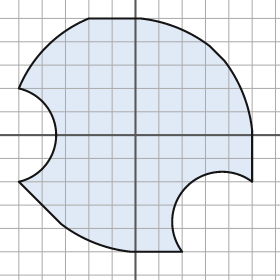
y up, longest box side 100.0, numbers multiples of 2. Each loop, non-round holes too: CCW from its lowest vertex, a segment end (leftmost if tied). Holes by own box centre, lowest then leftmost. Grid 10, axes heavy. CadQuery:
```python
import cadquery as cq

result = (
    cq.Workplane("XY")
    .moveTo(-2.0, -50.0)
    .lineTo(20.0, -50.0)
    .threePointArc((22.0, -22.0), (50.0, -20.0))
    .lineTo(50.0, 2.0)
    .threePointArc((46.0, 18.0), (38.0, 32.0))
    .lineTo(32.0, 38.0)
    .threePointArc((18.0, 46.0), (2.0, 50.0))
    .lineTo(-20.0, 50.0)
    .threePointArc((-38.0, 38.0), (-50.0, 20.0))
    .threePointArc((-34.0, 0.0), (-50.0, -20.0))
    .lineTo(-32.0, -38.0)
    .threePointArc((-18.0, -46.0), (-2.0, -50.0))
    .close()
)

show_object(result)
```